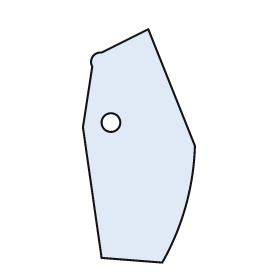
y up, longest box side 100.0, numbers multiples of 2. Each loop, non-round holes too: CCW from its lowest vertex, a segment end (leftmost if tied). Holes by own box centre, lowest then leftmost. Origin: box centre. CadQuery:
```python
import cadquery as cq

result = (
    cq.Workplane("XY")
    .moveTo(10.0, -50.0)
    .threePointArc((20.0, -26.0), (24.0, 0.0))
    .lineTo(4.0, 50.0)
    .lineTo(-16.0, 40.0)
    .threePointArc((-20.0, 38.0), (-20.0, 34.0))
    .lineTo(-24.0, 8.0)
    .lineTo(-16.0, -48.0)
    .close()
    .moveTo(-12.0, 10.0)
    .circle(4.0)
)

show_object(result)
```